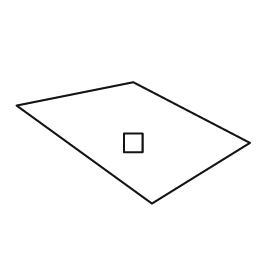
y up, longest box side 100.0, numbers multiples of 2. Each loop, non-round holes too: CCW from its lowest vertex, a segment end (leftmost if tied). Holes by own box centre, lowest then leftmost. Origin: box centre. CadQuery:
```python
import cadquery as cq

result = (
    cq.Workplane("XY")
    .moveTo(8.0, -26.0)
    .lineTo(50.0, 0.0)
    .lineTo(0.0, 26.0)
    .lineTo(-50.0, 16.0)
    .close()
    .moveTo(-4.0, -4.0)
    .lineTo(4.0, -4.0)
    .lineTo(4.0, 4.0)
    .lineTo(-4.0, 4.0)
    .close()
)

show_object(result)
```